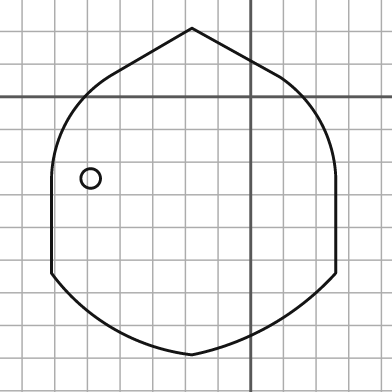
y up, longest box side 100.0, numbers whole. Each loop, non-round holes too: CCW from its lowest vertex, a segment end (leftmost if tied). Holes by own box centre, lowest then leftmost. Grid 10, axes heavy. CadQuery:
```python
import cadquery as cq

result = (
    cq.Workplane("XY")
    .moveTo(-18.0, -79.0)
    .threePointArc((6.0, -70.0), (26.0, -54.0))
    .lineTo(26.0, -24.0)
    .threePointArc((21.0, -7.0), (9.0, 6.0))
    .lineTo(-18.0, 21.0)
    .lineTo(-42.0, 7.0)
    .threePointArc((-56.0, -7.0), (-61.0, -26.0))
    .lineTo(-61.0, -54.0)
    .threePointArc((-42.0, -71.0), (-18.0, -79.0))
    .close()
    .moveTo(-49.0, -25.0)
    .circle(3.0)
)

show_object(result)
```